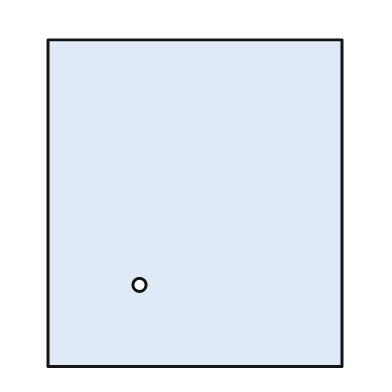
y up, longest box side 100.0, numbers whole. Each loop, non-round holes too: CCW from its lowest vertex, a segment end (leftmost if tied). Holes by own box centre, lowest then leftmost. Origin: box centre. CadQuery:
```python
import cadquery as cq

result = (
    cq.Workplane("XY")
    .moveTo(-45.0, -50.0)
    .lineTo(45.0, -50.0)
    .lineTo(45.0, 50.0)
    .lineTo(-45.0, 50.0)
    .close()
    .moveTo(-17.0, -25.0)
    .circle(2.0)
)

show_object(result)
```